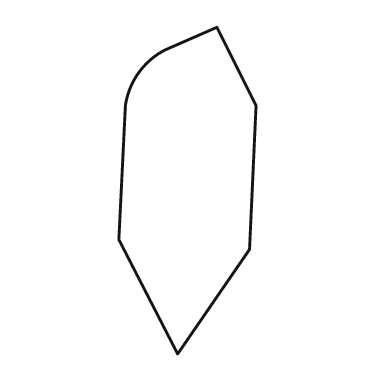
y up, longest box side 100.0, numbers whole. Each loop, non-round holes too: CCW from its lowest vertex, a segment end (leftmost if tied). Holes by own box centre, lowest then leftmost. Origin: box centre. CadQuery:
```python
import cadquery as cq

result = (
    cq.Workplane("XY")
    .moveTo(-3.0, -50.0)
    .lineTo(19.0, -18.0)
    .lineTo(21.0, 26.0)
    .lineTo(9.0, 50.0)
    .lineTo(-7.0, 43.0)
    .threePointArc((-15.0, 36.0), (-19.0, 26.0))
    .lineTo(-21.0, -15.0)
    .close()
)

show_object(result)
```